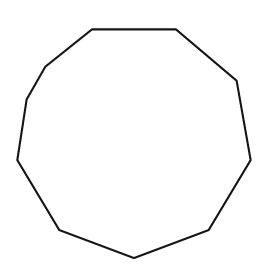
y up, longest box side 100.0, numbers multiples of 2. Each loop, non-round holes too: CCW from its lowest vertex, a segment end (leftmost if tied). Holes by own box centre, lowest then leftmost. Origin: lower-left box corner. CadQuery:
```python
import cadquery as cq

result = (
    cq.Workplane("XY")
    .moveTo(50.0, 0.0)
    .lineTo(82.0, 12.0)
    .lineTo(100.0, 42.0)
    .lineTo(94.0, 76.0)
    .lineTo(68.0, 98.0)
    .lineTo(32.0, 98.0)
    .lineTo(12.0, 82.0)
    .lineTo(4.0, 68.0)
    .lineTo(0.0, 42.0)
    .lineTo(18.0, 12.0)
    .close()
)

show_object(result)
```